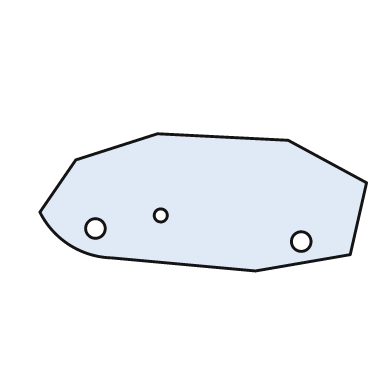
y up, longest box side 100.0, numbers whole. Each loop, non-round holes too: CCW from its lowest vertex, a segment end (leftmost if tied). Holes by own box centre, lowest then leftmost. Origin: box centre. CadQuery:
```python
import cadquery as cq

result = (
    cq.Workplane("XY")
    .moveTo(16.0, -21.0)
    .lineTo(45.0, -16.0)
    .lineTo(50.0, 6.0)
    .lineTo(26.0, 19.0)
    .lineTo(-14.0, 21.0)
    .lineTo(-39.0, 13.0)
    .lineTo(-50.0, -3.0)
    .threePointArc((-41.0, -13.0), (-28.0, -17.0))
    .close()
    .moveTo(30.0, -12.0)
    .circle(3.0)
    .moveTo(-33.0, -8.0)
    .circle(3.0)
    .moveTo(-13.0, -4.0)
    .circle(2.0)
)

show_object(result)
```